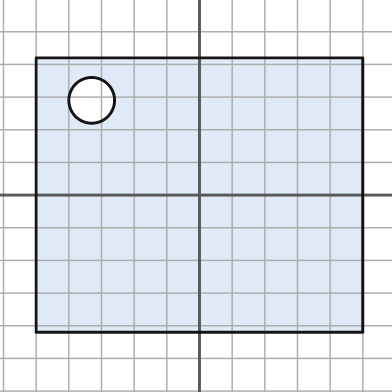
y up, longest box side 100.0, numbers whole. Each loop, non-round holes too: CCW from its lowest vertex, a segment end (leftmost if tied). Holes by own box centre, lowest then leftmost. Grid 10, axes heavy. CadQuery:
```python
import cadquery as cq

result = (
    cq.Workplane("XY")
    .moveTo(-50.0, -42.0)
    .lineTo(50.0, -42.0)
    .lineTo(50.0, 42.0)
    .lineTo(-50.0, 42.0)
    .close()
    .moveTo(-33.0, 29.0)
    .circle(7.0)
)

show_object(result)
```